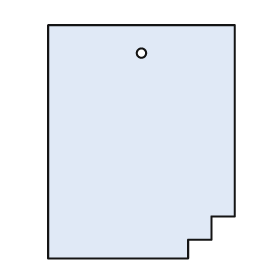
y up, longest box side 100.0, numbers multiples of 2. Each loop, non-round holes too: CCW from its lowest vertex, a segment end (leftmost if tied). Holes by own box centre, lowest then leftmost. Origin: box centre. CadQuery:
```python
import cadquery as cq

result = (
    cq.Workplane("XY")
    .moveTo(-40.0, -50.0)
    .lineTo(20.0, -50.0)
    .lineTo(20.0, -42.0)
    .lineTo(30.0, -42.0)
    .lineTo(30.0, -32.0)
    .lineTo(40.0, -32.0)
    .lineTo(40.0, 50.0)
    .lineTo(-40.0, 50.0)
    .close()
    .moveTo(0.0, 38.0)
    .circle(2.0)
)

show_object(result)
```